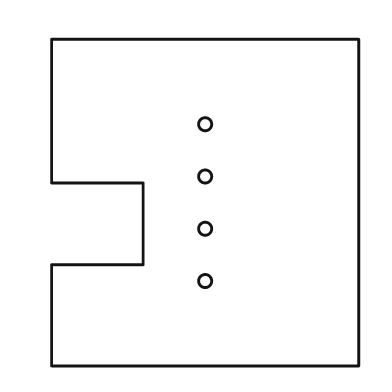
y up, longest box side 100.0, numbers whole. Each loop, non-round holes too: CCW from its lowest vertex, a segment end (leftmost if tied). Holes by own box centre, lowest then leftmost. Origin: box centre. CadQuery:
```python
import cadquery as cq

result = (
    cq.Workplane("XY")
    .moveTo(-47.0, -50.0)
    .lineTo(47.0, -50.0)
    .lineTo(47.0, 50.0)
    .lineTo(-47.0, 50.0)
    .lineTo(-47.0, 6.0)
    .lineTo(-19.0, 6.0)
    .lineTo(-19.0, -19.0)
    .lineTo(-47.0, -19.0)
    .close()
    .moveTo(0.0, -24.0)
    .circle(2.0)
    .moveTo(0.0, -8.0)
    .circle(2.0)
    .moveTo(0.0, 8.0)
    .circle(2.0)
    .moveTo(0.0, 24.0)
    .circle(2.0)
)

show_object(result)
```